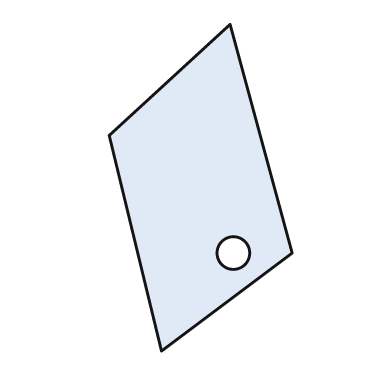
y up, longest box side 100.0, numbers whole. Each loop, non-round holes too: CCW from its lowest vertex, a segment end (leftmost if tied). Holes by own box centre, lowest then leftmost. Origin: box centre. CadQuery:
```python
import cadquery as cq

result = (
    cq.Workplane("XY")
    .moveTo(-12.0, -50.0)
    .lineTo(28.0, -20.0)
    .lineTo(9.0, 50.0)
    .lineTo(-28.0, 16.0)
    .close()
    .moveTo(10.0, -20.0)
    .circle(5.0)
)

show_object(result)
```